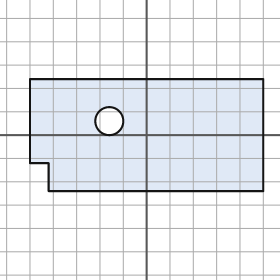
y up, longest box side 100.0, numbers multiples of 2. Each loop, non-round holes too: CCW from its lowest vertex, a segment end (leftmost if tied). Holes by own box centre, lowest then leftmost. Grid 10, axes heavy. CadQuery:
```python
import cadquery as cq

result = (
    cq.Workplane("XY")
    .moveTo(-42.0, -24.0)
    .lineTo(50.0, -24.0)
    .lineTo(50.0, 24.0)
    .lineTo(-50.0, 24.0)
    .lineTo(-50.0, -12.0)
    .lineTo(-42.0, -12.0)
    .close()
    .moveTo(-16.0, 6.0)
    .circle(6.0)
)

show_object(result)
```